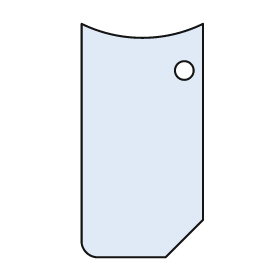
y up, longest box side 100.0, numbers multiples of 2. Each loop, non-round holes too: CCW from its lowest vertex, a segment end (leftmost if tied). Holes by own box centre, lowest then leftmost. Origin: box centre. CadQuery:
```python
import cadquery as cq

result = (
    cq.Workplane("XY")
    .moveTo(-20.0, -50.0)
    .lineTo(10.0, -50.0)
    .lineTo(26.0, -34.0)
    .lineTo(26.0, 50.0)
    .threePointArc((0.0, 44.0), (-26.0, 50.0))
    .lineTo(-26.0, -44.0)
    .threePointArc((-24.0, -48.0), (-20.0, -50.0))
    .close()
    .moveTo(18.0, 30.0)
    .circle(4.0)
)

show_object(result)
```